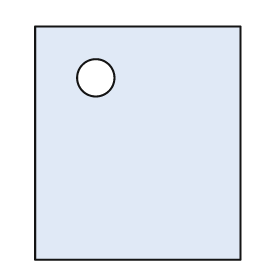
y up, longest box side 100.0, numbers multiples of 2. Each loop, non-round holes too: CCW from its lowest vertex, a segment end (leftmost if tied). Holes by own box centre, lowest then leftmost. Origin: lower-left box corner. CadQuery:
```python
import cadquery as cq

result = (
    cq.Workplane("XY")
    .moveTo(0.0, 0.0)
    .lineTo(88.0, 0.0)
    .lineTo(88.0, 100.0)
    .lineTo(0.0, 100.0)
    .close()
    .moveTo(26.0, 78.0)
    .circle(8.0)
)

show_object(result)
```